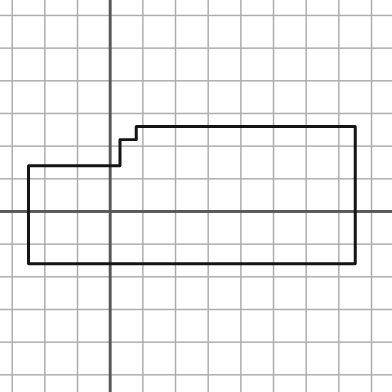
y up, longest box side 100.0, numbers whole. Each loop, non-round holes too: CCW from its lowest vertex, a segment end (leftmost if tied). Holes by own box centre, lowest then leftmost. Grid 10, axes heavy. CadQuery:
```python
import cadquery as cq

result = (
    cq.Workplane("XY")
    .moveTo(-25.0, -16.0)
    .lineTo(75.0, -16.0)
    .lineTo(75.0, 26.0)
    .lineTo(8.0, 26.0)
    .lineTo(8.0, 22.0)
    .lineTo(3.0, 22.0)
    .lineTo(3.0, 14.0)
    .lineTo(-25.0, 14.0)
    .close()
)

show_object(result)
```